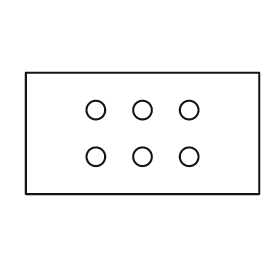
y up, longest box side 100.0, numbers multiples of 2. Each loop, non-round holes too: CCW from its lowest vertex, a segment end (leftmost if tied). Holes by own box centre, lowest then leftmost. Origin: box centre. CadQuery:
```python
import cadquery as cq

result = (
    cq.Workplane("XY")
    .moveTo(-50.0, -26.0)
    .lineTo(50.0, -26.0)
    .lineTo(50.0, 26.0)
    .lineTo(-50.0, 26.0)
    .close()
    .moveTo(-20.0, -10.0)
    .circle(4.0)
    .moveTo(0.0, -10.0)
    .circle(4.0)
    .moveTo(20.0, -10.0)
    .circle(4.0)
    .moveTo(-20.0, 10.0)
    .circle(4.0)
    .moveTo(0.0, 10.0)
    .circle(4.0)
    .moveTo(20.0, 10.0)
    .circle(4.0)
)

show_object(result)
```